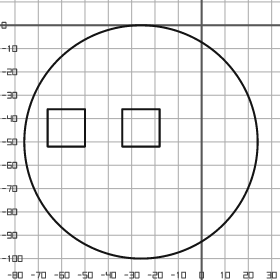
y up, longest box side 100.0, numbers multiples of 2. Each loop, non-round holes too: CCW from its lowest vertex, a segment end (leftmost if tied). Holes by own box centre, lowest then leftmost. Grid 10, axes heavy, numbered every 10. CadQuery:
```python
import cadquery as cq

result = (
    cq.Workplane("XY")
    .moveTo(-26.0, -50.0)
    .circle(50.0)
    .moveTo(-66.0, -52.0)
    .lineTo(-50.0, -52.0)
    .lineTo(-50.0, -36.0)
    .lineTo(-66.0, -36.0)
    .close()
    .moveTo(-34.0, -52.0)
    .lineTo(-18.0, -52.0)
    .lineTo(-18.0, -36.0)
    .lineTo(-34.0, -36.0)
    .close()
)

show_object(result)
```